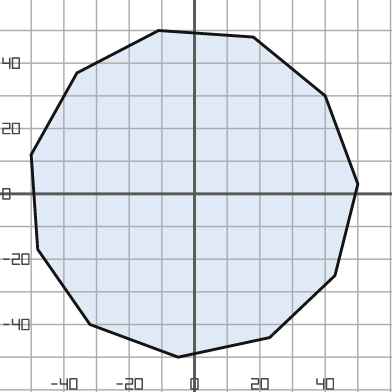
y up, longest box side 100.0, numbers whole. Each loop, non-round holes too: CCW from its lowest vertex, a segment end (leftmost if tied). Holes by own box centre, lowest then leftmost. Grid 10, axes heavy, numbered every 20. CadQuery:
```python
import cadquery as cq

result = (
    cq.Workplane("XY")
    .moveTo(-5.0, -50.0)
    .lineTo(23.0, -44.0)
    .lineTo(43.0, -25.0)
    .lineTo(50.0, 3.0)
    .lineTo(40.0, 30.0)
    .lineTo(18.0, 48.0)
    .lineTo(-11.0, 50.0)
    .lineTo(-36.0, 37.0)
    .lineTo(-50.0, 12.0)
    .lineTo(-48.0, -17.0)
    .lineTo(-32.0, -40.0)
    .close()
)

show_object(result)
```